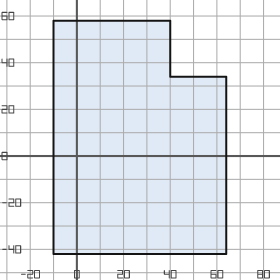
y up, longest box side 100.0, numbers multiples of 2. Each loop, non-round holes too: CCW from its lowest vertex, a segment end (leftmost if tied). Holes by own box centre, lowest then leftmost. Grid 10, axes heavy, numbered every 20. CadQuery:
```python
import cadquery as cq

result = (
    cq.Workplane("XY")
    .moveTo(-10.0, -42.0)
    .lineTo(64.0, -42.0)
    .lineTo(64.0, 34.0)
    .lineTo(40.0, 34.0)
    .lineTo(40.0, 58.0)
    .lineTo(-10.0, 58.0)
    .close()
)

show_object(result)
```